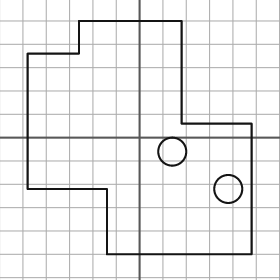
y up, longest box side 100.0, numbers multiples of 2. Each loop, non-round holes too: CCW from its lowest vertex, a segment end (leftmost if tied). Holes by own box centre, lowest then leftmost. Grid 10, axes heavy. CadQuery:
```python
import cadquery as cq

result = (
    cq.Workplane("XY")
    .moveTo(-14.0, -50.0)
    .lineTo(48.0, -50.0)
    .lineTo(48.0, 6.0)
    .lineTo(18.0, 6.0)
    .lineTo(18.0, 50.0)
    .lineTo(-26.0, 50.0)
    .lineTo(-26.0, 36.0)
    .lineTo(-48.0, 36.0)
    .lineTo(-48.0, -22.0)
    .lineTo(-14.0, -22.0)
    .close()
    .moveTo(38.0, -22.0)
    .circle(6.0)
    .moveTo(14.0, -6.0)
    .circle(6.0)
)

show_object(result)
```